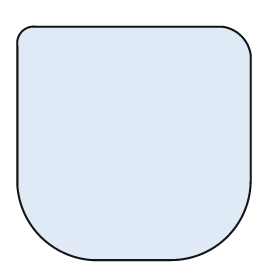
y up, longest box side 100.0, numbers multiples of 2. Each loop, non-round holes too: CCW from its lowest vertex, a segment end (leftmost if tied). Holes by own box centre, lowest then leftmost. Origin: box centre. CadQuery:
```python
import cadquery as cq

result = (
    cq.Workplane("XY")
    .moveTo(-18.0, -50.0)
    .lineTo(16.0, -50.0)
    .threePointArc((40.0, -40.0), (50.0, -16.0))
    .lineTo(50.0, 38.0)
    .threePointArc((46.0, 46.0), (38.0, 50.0))
    .lineTo(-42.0, 50.0)
    .threePointArc((-48.0, 48.0), (-50.0, 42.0))
    .lineTo(-50.0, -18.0)
    .threePointArc((-40.0, -40.0), (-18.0, -50.0))
    .close()
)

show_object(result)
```